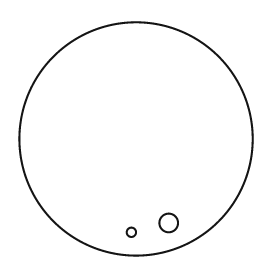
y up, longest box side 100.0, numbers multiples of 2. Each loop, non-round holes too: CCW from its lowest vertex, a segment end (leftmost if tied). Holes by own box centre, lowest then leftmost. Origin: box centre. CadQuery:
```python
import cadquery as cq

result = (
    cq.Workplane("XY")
    .moveTo(0.0, 0.0)
    .circle(50.0)
    .moveTo(-2.0, -40.0)
    .circle(2.0)
    .moveTo(14.0, -36.0)
    .circle(4.0)
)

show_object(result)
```